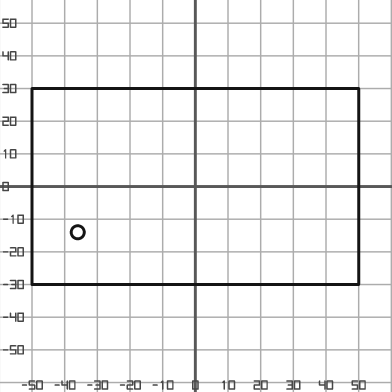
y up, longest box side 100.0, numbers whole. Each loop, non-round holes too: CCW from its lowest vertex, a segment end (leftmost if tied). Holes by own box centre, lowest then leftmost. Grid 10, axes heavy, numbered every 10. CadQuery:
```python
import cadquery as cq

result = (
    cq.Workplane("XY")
    .moveTo(-50.0, -30.0)
    .lineTo(50.0, -30.0)
    .lineTo(50.0, 30.0)
    .lineTo(-50.0, 30.0)
    .close()
    .moveTo(-36.0, -14.0)
    .circle(2.0)
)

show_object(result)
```